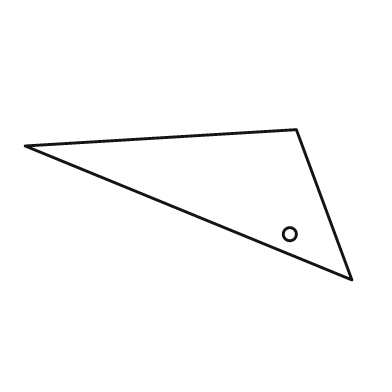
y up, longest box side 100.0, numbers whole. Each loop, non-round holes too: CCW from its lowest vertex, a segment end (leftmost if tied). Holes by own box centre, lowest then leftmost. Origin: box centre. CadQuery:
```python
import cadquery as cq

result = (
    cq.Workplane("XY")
    .moveTo(50.0, -23.0)
    .lineTo(33.0, 23.0)
    .lineTo(-50.0, 18.0)
    .close()
    .moveTo(31.0, -9.0)
    .circle(2.0)
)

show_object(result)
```